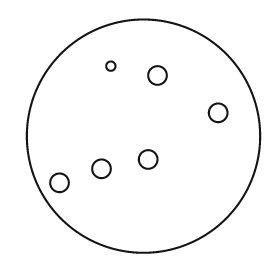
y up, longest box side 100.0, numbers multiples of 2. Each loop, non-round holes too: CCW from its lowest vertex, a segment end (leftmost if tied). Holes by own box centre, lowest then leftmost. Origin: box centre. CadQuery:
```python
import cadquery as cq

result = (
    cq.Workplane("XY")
    .moveTo(0.0, 0.0)
    .circle(50.0)
    .moveTo(-36.0, -20.0)
    .circle(4.0)
    .moveTo(-18.0, -14.0)
    .circle(4.0)
    .moveTo(2.0, -10.0)
    .circle(4.0)
    .moveTo(32.0, 10.0)
    .circle(4.0)
    .moveTo(6.0, 26.0)
    .circle(4.0)
    .moveTo(-14.0, 30.0)
    .circle(2.0)
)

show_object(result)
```